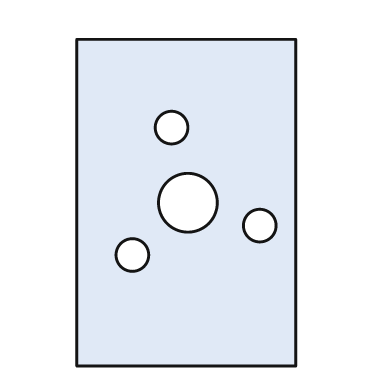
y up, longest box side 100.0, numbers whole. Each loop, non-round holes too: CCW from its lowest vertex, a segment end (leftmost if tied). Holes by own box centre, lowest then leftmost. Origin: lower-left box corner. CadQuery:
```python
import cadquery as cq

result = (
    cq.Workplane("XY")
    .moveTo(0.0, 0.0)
    .lineTo(67.0, 0.0)
    .lineTo(67.0, 100.0)
    .lineTo(0.0, 100.0)
    .close()
    .moveTo(17.0, 34.0)
    .circle(5.0)
    .moveTo(56.0, 43.0)
    .circle(5.0)
    .moveTo(34.0, 50.0)
    .circle(9.0)
    .moveTo(29.0, 73.0)
    .circle(5.0)
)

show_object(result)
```